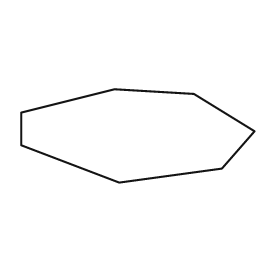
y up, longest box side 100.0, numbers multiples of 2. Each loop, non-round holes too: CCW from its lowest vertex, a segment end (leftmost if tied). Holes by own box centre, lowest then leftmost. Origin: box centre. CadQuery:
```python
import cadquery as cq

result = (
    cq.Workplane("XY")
    .moveTo(-8.0, -20.0)
    .lineTo(36.0, -14.0)
    .lineTo(50.0, 2.0)
    .lineTo(24.0, 18.0)
    .lineTo(-10.0, 20.0)
    .lineTo(-50.0, 10.0)
    .lineTo(-50.0, -4.0)
    .close()
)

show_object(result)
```